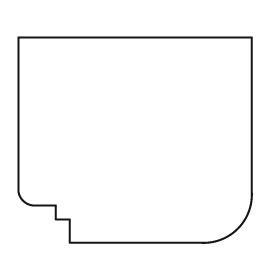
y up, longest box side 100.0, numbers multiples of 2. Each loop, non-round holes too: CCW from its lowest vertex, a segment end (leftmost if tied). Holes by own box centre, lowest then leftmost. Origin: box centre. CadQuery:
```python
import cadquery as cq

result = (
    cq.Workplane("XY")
    .moveTo(-28.0, -44.0)
    .lineTo(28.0, -44.0)
    .threePointArc((44.0, -38.0), (50.0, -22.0))
    .lineTo(50.0, 44.0)
    .lineTo(-50.0, 44.0)
    .lineTo(-50.0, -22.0)
    .threePointArc((-48.0, -26.0), (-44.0, -28.0))
    .lineTo(-34.0, -28.0)
    .lineTo(-34.0, -34.0)
    .lineTo(-28.0, -34.0)
    .close()
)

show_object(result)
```